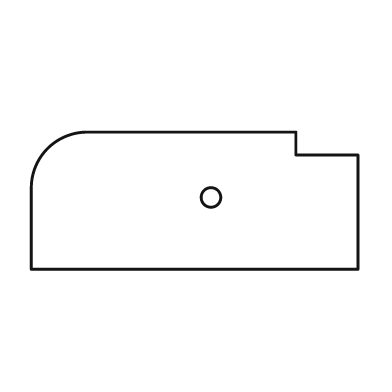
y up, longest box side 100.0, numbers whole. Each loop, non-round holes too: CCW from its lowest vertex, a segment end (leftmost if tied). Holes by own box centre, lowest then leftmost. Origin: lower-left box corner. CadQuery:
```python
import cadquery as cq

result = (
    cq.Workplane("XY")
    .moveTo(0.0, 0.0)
    .lineTo(100.0, 0.0)
    .lineTo(100.0, 35.0)
    .lineTo(81.0, 35.0)
    .lineTo(81.0, 42.0)
    .lineTo(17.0, 42.0)
    .threePointArc((5.0, 37.0), (0.0, 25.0))
    .close()
    .moveTo(55.0, 22.0)
    .circle(3.0)
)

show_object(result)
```